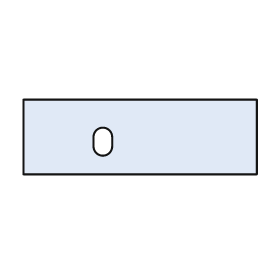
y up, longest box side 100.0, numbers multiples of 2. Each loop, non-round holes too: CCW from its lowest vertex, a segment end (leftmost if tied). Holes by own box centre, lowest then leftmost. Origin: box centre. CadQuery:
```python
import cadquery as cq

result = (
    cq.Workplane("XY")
    .moveTo(-50.0, -16.0)
    .lineTo(50.0, -16.0)
    .lineTo(50.0, 16.0)
    .lineTo(-50.0, 16.0)
    .close()
    .moveTo(-20.0, -4.0)
    .threePointArc((-16.0, -8.0), (-12.0, -4.0))
    .lineTo(-12.0, 0.0)
    .threePointArc((-16.0, 4.0), (-20.0, 0.0))
    .close()
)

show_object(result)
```